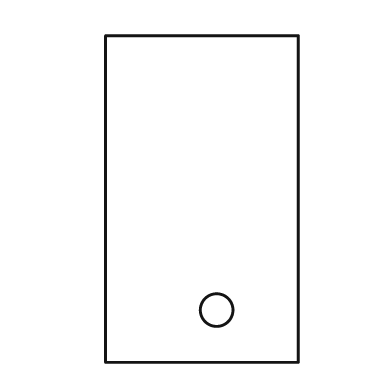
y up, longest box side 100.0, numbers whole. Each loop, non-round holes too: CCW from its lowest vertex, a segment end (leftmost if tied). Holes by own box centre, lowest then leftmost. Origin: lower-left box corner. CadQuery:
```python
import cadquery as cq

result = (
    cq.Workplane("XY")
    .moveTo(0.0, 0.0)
    .lineTo(59.0, 0.0)
    .lineTo(59.0, 100.0)
    .lineTo(0.0, 100.0)
    .close()
    .moveTo(34.0, 16.0)
    .circle(5.0)
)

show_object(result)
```